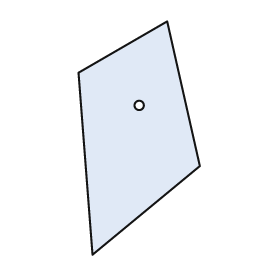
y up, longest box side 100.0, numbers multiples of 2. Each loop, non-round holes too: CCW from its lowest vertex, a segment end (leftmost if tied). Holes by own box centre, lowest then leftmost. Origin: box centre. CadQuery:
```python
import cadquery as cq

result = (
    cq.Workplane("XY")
    .moveTo(-20.0, -50.0)
    .lineTo(26.0, -12.0)
    .lineTo(12.0, 50.0)
    .lineTo(-26.0, 28.0)
    .close()
    .moveTo(0.0, 14.0)
    .circle(2.0)
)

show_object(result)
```